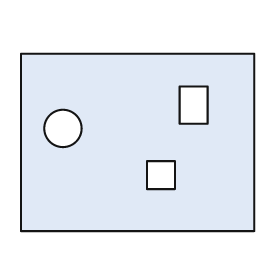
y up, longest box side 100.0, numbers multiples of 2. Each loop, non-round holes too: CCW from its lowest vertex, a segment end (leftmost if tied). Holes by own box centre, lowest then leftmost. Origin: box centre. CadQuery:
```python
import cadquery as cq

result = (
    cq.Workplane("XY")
    .moveTo(-50.0, -38.0)
    .lineTo(50.0, -38.0)
    .lineTo(50.0, 38.0)
    .lineTo(-50.0, 38.0)
    .close()
    .moveTo(4.0, -20.0)
    .lineTo(16.0, -20.0)
    .lineTo(16.0, -8.0)
    .lineTo(4.0, -8.0)
    .close()
    .moveTo(-32.0, 6.0)
    .circle(8.0)
    .moveTo(18.0, 8.0)
    .lineTo(30.0, 8.0)
    .lineTo(30.0, 24.0)
    .lineTo(18.0, 24.0)
    .close()
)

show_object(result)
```